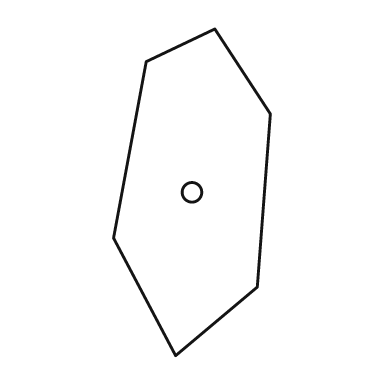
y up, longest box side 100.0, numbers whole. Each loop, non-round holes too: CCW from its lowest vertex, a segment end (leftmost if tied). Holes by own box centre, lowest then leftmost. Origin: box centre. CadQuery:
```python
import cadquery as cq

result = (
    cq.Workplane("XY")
    .moveTo(-5.0, -50.0)
    .lineTo(20.0, -29.0)
    .lineTo(24.0, 24.0)
    .lineTo(7.0, 50.0)
    .lineTo(-14.0, 40.0)
    .lineTo(-24.0, -14.0)
    .close()
    .moveTo(0.0, 0.0)
    .circle(3.0)
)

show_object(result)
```